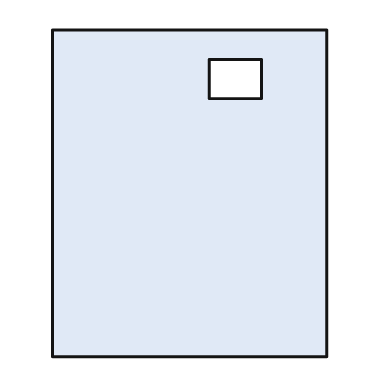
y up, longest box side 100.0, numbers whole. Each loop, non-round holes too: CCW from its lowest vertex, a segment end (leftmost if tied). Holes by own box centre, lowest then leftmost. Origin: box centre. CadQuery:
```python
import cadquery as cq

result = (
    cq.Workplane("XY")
    .moveTo(-42.0, -50.0)
    .lineTo(42.0, -50.0)
    .lineTo(42.0, 50.0)
    .lineTo(-42.0, 50.0)
    .close()
    .moveTo(6.0, 29.0)
    .lineTo(22.0, 29.0)
    .lineTo(22.0, 41.0)
    .lineTo(6.0, 41.0)
    .close()
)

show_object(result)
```